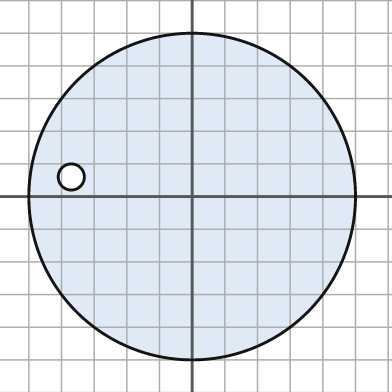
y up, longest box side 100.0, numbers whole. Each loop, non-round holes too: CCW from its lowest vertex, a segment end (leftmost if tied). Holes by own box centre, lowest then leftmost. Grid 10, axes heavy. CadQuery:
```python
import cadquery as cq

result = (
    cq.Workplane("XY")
    .moveTo(0.0, 0.0)
    .circle(50.0)
    .moveTo(-37.0, 6.0)
    .circle(4.0)
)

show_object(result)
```